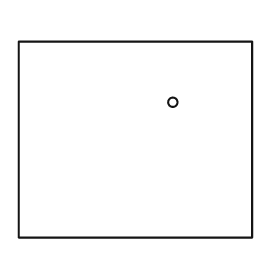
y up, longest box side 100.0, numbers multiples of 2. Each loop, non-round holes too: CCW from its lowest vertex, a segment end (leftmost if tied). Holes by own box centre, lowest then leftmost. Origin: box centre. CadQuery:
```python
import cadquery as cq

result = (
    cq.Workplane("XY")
    .moveTo(-50.0, -42.0)
    .lineTo(50.0, -42.0)
    .lineTo(50.0, 42.0)
    .lineTo(-50.0, 42.0)
    .close()
    .moveTo(16.0, 16.0)
    .circle(2.0)
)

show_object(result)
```